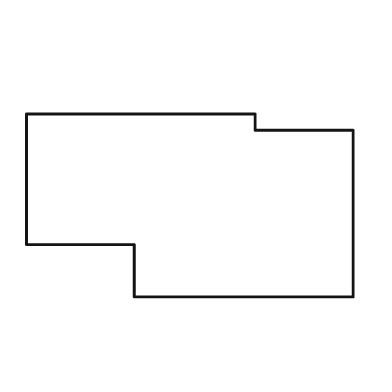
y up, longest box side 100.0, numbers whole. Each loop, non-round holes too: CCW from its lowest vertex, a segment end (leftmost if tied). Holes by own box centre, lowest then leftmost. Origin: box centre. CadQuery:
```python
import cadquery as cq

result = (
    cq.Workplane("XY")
    .moveTo(-17.0, -28.0)
    .lineTo(50.0, -28.0)
    .lineTo(50.0, 23.0)
    .lineTo(20.0, 23.0)
    .lineTo(20.0, 28.0)
    .lineTo(-50.0, 28.0)
    .lineTo(-50.0, -12.0)
    .lineTo(-17.0, -12.0)
    .close()
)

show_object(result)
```